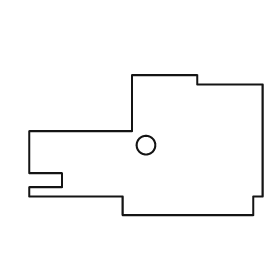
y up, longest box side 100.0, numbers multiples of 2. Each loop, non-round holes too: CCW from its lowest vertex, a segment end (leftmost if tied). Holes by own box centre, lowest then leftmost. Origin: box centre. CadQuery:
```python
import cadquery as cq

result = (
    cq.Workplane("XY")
    .moveTo(-10.0, -30.0)
    .lineTo(46.0, -30.0)
    .lineTo(46.0, -22.0)
    .lineTo(50.0, -22.0)
    .lineTo(50.0, 26.0)
    .lineTo(22.0, 26.0)
    .lineTo(22.0, 30.0)
    .lineTo(-6.0, 30.0)
    .lineTo(-6.0, 6.0)
    .lineTo(-50.0, 6.0)
    .lineTo(-50.0, -12.0)
    .lineTo(-36.0, -12.0)
    .lineTo(-36.0, -18.0)
    .lineTo(-50.0, -18.0)
    .lineTo(-50.0, -22.0)
    .lineTo(-10.0, -22.0)
    .close()
    .moveTo(0.0, 0.0)
    .circle(4.0)
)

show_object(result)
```